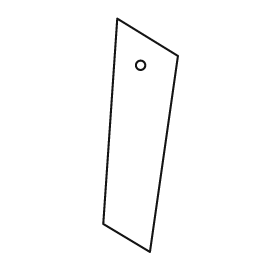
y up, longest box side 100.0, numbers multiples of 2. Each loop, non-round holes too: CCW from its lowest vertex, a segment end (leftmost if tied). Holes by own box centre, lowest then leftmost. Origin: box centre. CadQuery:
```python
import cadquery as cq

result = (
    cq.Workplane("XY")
    .moveTo(4.0, -50.0)
    .lineTo(16.0, 34.0)
    .lineTo(-10.0, 50.0)
    .lineTo(-16.0, -38.0)
    .close()
    .moveTo(0.0, 30.0)
    .circle(2.0)
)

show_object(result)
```